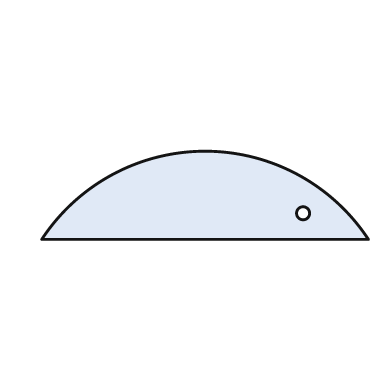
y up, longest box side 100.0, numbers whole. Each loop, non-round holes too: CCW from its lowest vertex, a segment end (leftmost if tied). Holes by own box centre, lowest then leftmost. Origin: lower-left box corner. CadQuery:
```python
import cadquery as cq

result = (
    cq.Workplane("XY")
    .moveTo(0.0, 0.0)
    .lineTo(100.0, 0.0)
    .threePointArc((50.0, 27.0), (0.0, 0.0))
    .close()
    .moveTo(80.0, 8.0)
    .circle(2.0)
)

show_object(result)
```